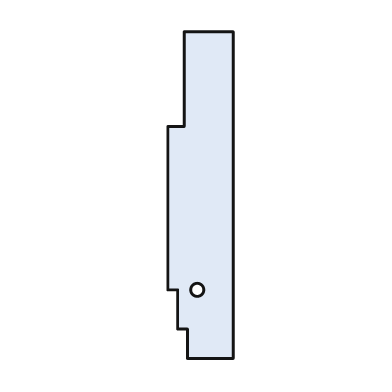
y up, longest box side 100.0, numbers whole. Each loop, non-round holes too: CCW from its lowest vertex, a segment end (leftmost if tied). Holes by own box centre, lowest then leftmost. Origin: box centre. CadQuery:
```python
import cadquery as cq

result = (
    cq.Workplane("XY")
    .moveTo(-4.0, -50.0)
    .lineTo(10.0, -50.0)
    .lineTo(10.0, 50.0)
    .lineTo(-5.0, 50.0)
    .lineTo(-5.0, 21.0)
    .lineTo(-10.0, 21.0)
    .lineTo(-10.0, -29.0)
    .lineTo(-7.0, -29.0)
    .lineTo(-7.0, -41.0)
    .lineTo(-4.0, -41.0)
    .close()
    .moveTo(-1.0, -29.0)
    .circle(2.0)
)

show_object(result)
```